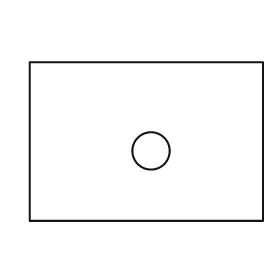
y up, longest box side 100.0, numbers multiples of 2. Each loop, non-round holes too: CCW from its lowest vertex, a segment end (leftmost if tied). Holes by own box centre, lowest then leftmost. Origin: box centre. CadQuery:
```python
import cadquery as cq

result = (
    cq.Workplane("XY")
    .moveTo(-50.0, -34.0)
    .lineTo(50.0, -34.0)
    .lineTo(50.0, 34.0)
    .lineTo(-50.0, 34.0)
    .close()
    .moveTo(2.0, -4.0)
    .circle(8.0)
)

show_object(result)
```